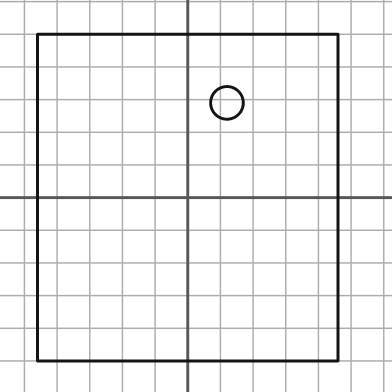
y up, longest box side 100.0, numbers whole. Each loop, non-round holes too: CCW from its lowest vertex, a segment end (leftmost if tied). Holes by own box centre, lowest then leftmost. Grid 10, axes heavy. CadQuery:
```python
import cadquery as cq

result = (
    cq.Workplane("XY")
    .moveTo(-46.0, -50.0)
    .lineTo(46.0, -50.0)
    .lineTo(46.0, 50.0)
    .lineTo(-46.0, 50.0)
    .close()
    .moveTo(12.0, 29.0)
    .circle(5.0)
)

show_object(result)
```